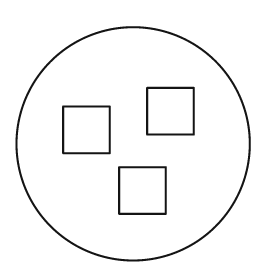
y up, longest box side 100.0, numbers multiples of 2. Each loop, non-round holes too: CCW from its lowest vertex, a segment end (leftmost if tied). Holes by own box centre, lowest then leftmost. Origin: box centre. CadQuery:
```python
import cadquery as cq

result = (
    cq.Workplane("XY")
    .moveTo(0.0, 0.0)
    .circle(50.0)
    .moveTo(-6.0, -30.0)
    .lineTo(14.0, -30.0)
    .lineTo(14.0, -10.0)
    .lineTo(-6.0, -10.0)
    .close()
    .moveTo(-30.0, -4.0)
    .lineTo(-10.0, -4.0)
    .lineTo(-10.0, 16.0)
    .lineTo(-30.0, 16.0)
    .close()
    .moveTo(6.0, 4.0)
    .lineTo(26.0, 4.0)
    .lineTo(26.0, 24.0)
    .lineTo(6.0, 24.0)
    .close()
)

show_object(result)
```